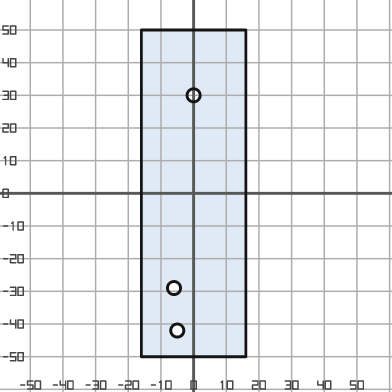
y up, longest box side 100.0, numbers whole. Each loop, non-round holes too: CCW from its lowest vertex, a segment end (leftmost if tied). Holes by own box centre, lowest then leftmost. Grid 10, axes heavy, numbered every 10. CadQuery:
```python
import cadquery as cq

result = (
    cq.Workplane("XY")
    .moveTo(-16.0, -50.0)
    .lineTo(16.0, -50.0)
    .lineTo(16.0, 50.0)
    .lineTo(-16.0, 50.0)
    .close()
    .moveTo(-5.0, -42.0)
    .circle(2.0)
    .moveTo(-6.0, -29.0)
    .circle(2.0)
    .moveTo(0.0, 30.0)
    .circle(2.0)
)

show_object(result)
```